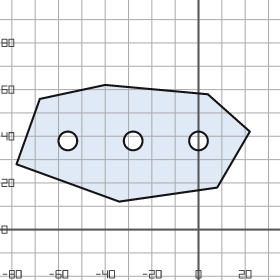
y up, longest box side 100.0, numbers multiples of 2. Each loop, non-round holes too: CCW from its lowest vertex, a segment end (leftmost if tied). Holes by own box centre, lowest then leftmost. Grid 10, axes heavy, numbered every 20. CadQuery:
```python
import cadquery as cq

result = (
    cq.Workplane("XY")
    .moveTo(-34.0, 12.0)
    .lineTo(8.0, 18.0)
    .lineTo(22.0, 42.0)
    .lineTo(4.0, 58.0)
    .lineTo(-40.0, 62.0)
    .lineTo(-68.0, 56.0)
    .lineTo(-78.0, 28.0)
    .close()
    .moveTo(-56.0, 38.0)
    .circle(4.0)
    .moveTo(-28.0, 38.0)
    .circle(4.0)
    .moveTo(0.0, 38.0)
    .circle(4.0)
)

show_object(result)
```